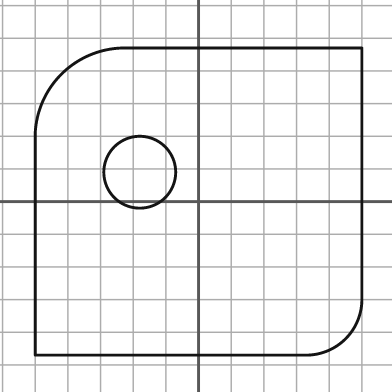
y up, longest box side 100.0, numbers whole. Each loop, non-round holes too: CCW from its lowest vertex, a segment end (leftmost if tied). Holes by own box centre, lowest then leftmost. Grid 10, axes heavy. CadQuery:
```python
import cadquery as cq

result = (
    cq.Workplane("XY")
    .moveTo(-50.0, -47.0)
    .lineTo(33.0, -47.0)
    .threePointArc((45.0, -42.0), (50.0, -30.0))
    .lineTo(50.0, 47.0)
    .lineTo(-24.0, 47.0)
    .threePointArc((-42.0, 39.0), (-50.0, 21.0))
    .close()
    .moveTo(-18.0, 9.0)
    .circle(11.0)
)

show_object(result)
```